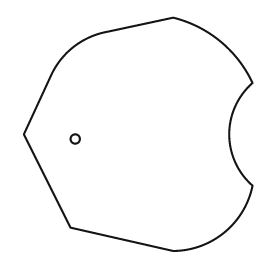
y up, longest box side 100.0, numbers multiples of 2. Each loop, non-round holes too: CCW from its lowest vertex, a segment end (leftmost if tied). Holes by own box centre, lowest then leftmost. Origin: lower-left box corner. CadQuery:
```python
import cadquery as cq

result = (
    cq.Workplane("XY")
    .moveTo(64.0, 0.0)
    .threePointArc((86.0, 8.0), (98.0, 28.0))
    .threePointArc((88.0, 50.0), (98.0, 72.0))
    .threePointArc((84.0, 90.0), (64.0, 100.0))
    .lineTo(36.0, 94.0)
    .threePointArc((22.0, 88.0), (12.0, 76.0))
    .lineTo(0.0, 50.0)
    .lineTo(20.0, 10.0)
    .close()
    .moveTo(22.0, 48.0)
    .circle(2.0)
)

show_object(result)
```